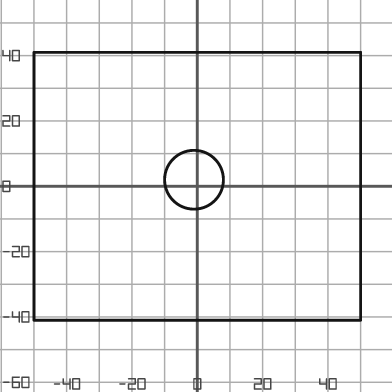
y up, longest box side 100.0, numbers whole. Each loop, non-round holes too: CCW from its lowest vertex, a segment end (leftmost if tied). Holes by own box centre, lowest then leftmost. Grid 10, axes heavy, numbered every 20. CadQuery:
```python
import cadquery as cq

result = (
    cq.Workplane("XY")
    .moveTo(-50.0, -41.0)
    .lineTo(50.0, -41.0)
    .lineTo(50.0, 41.0)
    .lineTo(-50.0, 41.0)
    .close()
    .moveTo(-1.0, 2.0)
    .circle(9.0)
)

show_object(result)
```